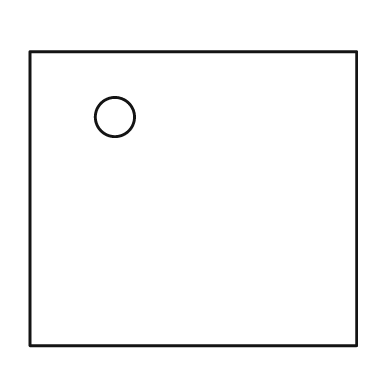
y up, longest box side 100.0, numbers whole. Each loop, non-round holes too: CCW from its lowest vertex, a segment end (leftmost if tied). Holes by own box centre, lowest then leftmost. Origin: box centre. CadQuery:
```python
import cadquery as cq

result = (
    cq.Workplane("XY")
    .moveTo(-50.0, -45.0)
    .lineTo(50.0, -45.0)
    .lineTo(50.0, 45.0)
    .lineTo(-50.0, 45.0)
    .close()
    .moveTo(-24.0, 25.0)
    .circle(6.0)
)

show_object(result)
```